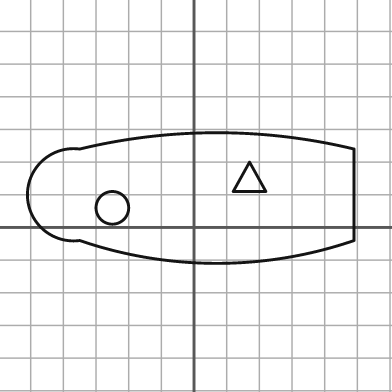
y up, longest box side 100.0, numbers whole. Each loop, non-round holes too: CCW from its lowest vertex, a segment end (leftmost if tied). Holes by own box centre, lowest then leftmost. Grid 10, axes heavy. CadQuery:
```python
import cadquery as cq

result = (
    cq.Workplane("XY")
    .moveTo(-35.0, -4.0)
    .threePointArc((7.0, -11.0), (49.0, -4.0))
    .lineTo(49.0, 24.0)
    .threePointArc((7.0, 29.0), (-35.0, 24.0))
    .threePointArc((-51.0, 10.0), (-35.0, -4.0))
    .close()
    .moveTo(-25.0, 6.0)
    .circle(5.0)
    .moveTo(12.0, 11.0)
    .lineTo(22.0, 11.0)
    .lineTo(17.0, 20.0)
    .close()
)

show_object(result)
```